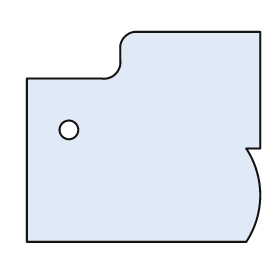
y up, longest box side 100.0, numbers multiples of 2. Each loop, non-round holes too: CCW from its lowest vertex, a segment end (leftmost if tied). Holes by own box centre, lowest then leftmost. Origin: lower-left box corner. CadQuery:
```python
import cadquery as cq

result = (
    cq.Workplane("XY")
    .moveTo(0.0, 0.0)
    .lineTo(94.0, 0.0)
    .threePointArc((100.0, 20.0), (94.0, 40.0))
    .lineTo(100.0, 40.0)
    .lineTo(100.0, 90.0)
    .lineTo(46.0, 90.0)
    .threePointArc((42.0, 88.0), (40.0, 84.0))
    .lineTo(40.0, 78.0)
    .threePointArc((38.0, 72.0), (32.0, 70.0))
    .lineTo(0.0, 70.0)
    .close()
    .moveTo(18.0, 48.0)
    .circle(4.0)
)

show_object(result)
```